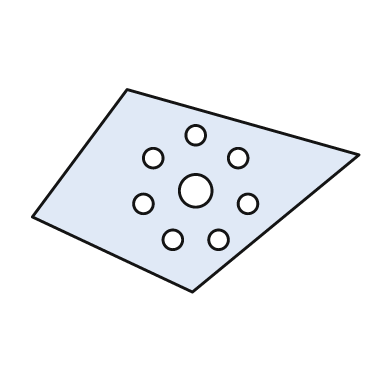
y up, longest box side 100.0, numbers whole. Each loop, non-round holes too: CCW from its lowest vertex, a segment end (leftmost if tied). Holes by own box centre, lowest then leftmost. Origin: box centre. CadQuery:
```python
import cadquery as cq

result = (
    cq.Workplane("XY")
    .moveTo(-1.0, -31.0)
    .lineTo(50.0, 11.0)
    .lineTo(-21.0, 31.0)
    .lineTo(-50.0, -8.0)
    .close()
    .moveTo(-7.0, -15.0)
    .circle(3.0)
    .moveTo(7.0, -15.0)
    .circle(3.0)
    .moveTo(-16.0, -4.0)
    .circle(3.0)
    .moveTo(16.0, -4.0)
    .circle(3.0)
    .moveTo(0.0, 0.0)
    .circle(5.0)
    .moveTo(-13.0, 10.0)
    .circle(3.0)
    .moveTo(13.0, 10.0)
    .circle(3.0)
    .moveTo(0.0, 17.0)
    .circle(3.0)
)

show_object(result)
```